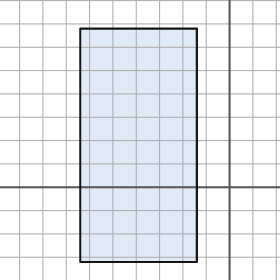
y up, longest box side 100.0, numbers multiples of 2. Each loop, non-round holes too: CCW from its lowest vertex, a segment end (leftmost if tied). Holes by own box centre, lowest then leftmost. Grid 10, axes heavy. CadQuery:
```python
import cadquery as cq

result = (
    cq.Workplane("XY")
    .moveTo(-64.0, -32.0)
    .lineTo(-14.0, -32.0)
    .lineTo(-14.0, 68.0)
    .lineTo(-64.0, 68.0)
    .close()
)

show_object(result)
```